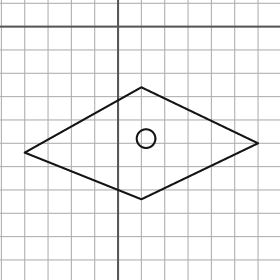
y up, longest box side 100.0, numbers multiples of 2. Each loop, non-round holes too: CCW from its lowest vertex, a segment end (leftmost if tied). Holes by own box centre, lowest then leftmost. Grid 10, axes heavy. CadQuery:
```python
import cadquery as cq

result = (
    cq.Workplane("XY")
    .moveTo(10.0, -74.0)
    .lineTo(60.0, -50.0)
    .lineTo(10.0, -26.0)
    .lineTo(-40.0, -54.0)
    .close()
    .moveTo(12.0, -48.0)
    .circle(4.0)
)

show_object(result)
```